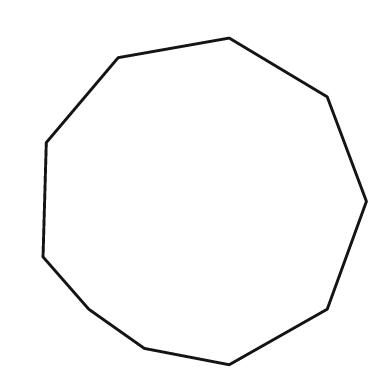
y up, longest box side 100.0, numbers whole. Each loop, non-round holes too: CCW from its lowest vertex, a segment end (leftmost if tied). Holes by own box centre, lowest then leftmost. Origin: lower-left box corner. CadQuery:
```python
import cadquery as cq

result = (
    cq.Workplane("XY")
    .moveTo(57.0, 0.0)
    .lineTo(87.0, 17.0)
    .lineTo(99.0, 50.0)
    .lineTo(87.0, 82.0)
    .lineTo(57.0, 100.0)
    .lineTo(23.0, 94.0)
    .lineTo(1.0, 68.0)
    .lineTo(0.0, 33.0)
    .lineTo(14.0, 17.0)
    .lineTo(31.0, 5.0)
    .close()
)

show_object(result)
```